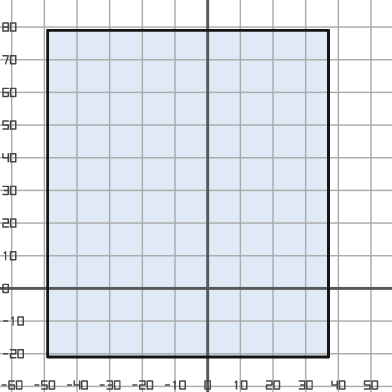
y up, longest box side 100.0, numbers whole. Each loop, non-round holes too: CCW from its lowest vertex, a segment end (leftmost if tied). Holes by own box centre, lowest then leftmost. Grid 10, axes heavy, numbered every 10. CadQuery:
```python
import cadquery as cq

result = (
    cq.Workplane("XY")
    .moveTo(-49.0, -21.0)
    .lineTo(37.0, -21.0)
    .lineTo(37.0, 79.0)
    .lineTo(-49.0, 79.0)
    .close()
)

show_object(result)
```